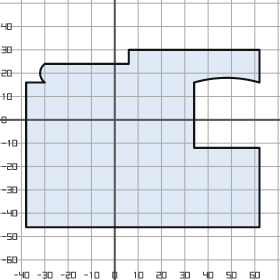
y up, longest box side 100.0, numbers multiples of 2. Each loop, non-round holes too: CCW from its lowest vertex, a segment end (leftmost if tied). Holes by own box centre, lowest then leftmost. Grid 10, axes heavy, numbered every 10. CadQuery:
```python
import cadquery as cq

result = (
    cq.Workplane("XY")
    .moveTo(-38.0, -46.0)
    .lineTo(62.0, -46.0)
    .lineTo(62.0, -12.0)
    .lineTo(34.0, -12.0)
    .lineTo(34.0, 16.0)
    .threePointArc((48.0, 18.0), (62.0, 16.0))
    .lineTo(62.0, 30.0)
    .lineTo(6.0, 30.0)
    .lineTo(6.0, 24.0)
    .lineTo(-30.0, 24.0)
    .threePointArc((-32.0, 20.0), (-30.0, 16.0))
    .lineTo(-38.0, 16.0)
    .close()
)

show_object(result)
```